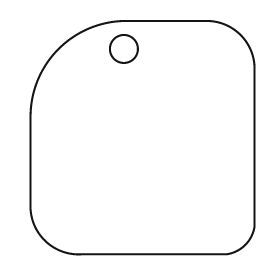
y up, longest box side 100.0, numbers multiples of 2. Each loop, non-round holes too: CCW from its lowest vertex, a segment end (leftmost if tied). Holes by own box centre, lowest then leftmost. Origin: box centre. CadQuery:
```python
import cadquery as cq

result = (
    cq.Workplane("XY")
    .moveTo(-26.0, -50.0)
    .lineTo(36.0, -50.0)
    .threePointArc((44.0, -46.0), (48.0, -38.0))
    .lineTo(48.0, 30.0)
    .threePointArc((42.0, 44.0), (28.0, 50.0))
    .lineTo(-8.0, 50.0)
    .threePointArc((-36.0, 38.0), (-48.0, 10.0))
    .lineTo(-48.0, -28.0)
    .threePointArc((-42.0, -44.0), (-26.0, -50.0))
    .close()
    .moveTo(-8.0, 38.0)
    .circle(6.0)
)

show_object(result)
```